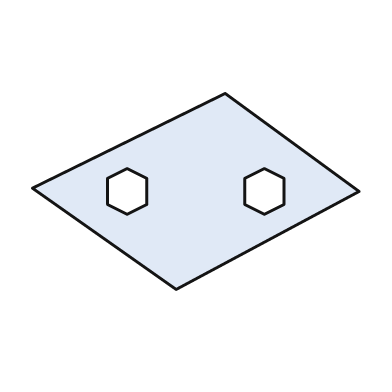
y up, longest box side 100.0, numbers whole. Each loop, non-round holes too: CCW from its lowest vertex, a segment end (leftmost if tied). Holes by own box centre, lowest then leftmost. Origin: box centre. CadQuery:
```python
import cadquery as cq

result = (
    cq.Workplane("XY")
    .moveTo(-6.0, -30.0)
    .lineTo(50.0, 0.0)
    .lineTo(9.0, 30.0)
    .lineTo(-50.0, 1.0)
    .close()
    .moveTo(-21.0, -7.0)
    .lineTo(-15.0, -4.0)
    .lineTo(-15.0, 4.0)
    .lineTo(-21.0, 7.0)
    .lineTo(-27.0, 4.0)
    .lineTo(-27.0, -4.0)
    .close()
    .moveTo(21.0, -7.0)
    .lineTo(27.0, -4.0)
    .lineTo(27.0, 4.0)
    .lineTo(21.0, 7.0)
    .lineTo(15.0, 4.0)
    .lineTo(15.0, -4.0)
    .close()
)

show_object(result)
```